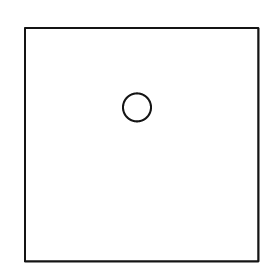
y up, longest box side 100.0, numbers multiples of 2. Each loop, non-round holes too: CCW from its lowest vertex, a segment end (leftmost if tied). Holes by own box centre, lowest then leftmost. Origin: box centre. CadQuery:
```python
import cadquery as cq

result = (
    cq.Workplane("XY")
    .moveTo(-50.0, -50.0)
    .lineTo(50.0, -50.0)
    .lineTo(50.0, 50.0)
    .lineTo(-50.0, 50.0)
    .close()
    .moveTo(-2.0, 16.0)
    .circle(6.0)
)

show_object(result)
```